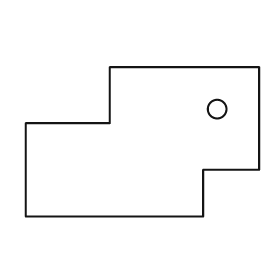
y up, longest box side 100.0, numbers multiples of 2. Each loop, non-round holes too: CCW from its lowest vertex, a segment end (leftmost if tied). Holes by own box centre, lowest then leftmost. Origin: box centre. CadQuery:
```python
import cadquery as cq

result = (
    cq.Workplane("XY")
    .moveTo(-50.0, -32.0)
    .lineTo(26.0, -32.0)
    .lineTo(26.0, -12.0)
    .lineTo(50.0, -12.0)
    .lineTo(50.0, 32.0)
    .lineTo(-14.0, 32.0)
    .lineTo(-14.0, 8.0)
    .lineTo(-50.0, 8.0)
    .close()
    .moveTo(32.0, 14.0)
    .circle(4.0)
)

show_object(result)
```